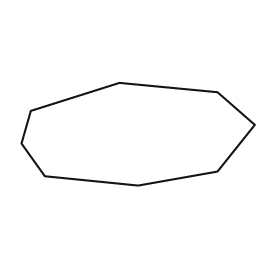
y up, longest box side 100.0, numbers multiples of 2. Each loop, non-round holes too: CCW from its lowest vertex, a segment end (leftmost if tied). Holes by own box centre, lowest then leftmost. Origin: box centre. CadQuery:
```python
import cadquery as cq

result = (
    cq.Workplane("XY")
    .moveTo(0.0, -22.0)
    .lineTo(34.0, -16.0)
    .lineTo(50.0, 4.0)
    .lineTo(34.0, 18.0)
    .lineTo(-8.0, 22.0)
    .lineTo(-46.0, 10.0)
    .lineTo(-50.0, -4.0)
    .lineTo(-40.0, -18.0)
    .close()
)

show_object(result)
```